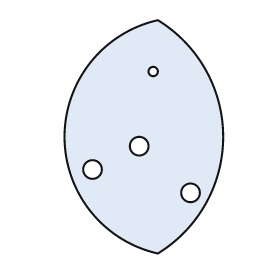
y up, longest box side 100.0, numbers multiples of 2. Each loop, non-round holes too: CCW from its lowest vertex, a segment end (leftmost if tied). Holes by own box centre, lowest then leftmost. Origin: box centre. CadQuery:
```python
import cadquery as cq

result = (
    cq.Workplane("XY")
    .moveTo(6.0, -50.0)
    .threePointArc((34.0, 0.0), (6.0, 50.0))
    .threePointArc((-34.0, 0.0), (6.0, -50.0))
    .close()
    .moveTo(20.0, -24.0)
    .circle(4.0)
    .moveTo(-22.0, -14.0)
    .circle(4.0)
    .moveTo(-2.0, -4.0)
    .circle(4.0)
    .moveTo(4.0, 28.0)
    .circle(2.0)
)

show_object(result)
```